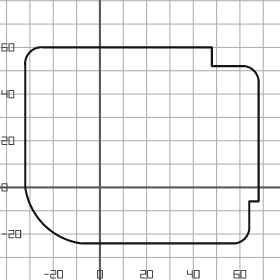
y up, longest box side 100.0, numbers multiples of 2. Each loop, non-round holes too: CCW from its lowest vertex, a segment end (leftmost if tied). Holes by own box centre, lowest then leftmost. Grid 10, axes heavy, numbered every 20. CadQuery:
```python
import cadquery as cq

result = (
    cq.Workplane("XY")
    .moveTo(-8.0, -24.0)
    .lineTo(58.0, -24.0)
    .threePointArc((62.0, -22.0), (64.0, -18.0))
    .lineTo(64.0, -6.0)
    .lineTo(68.0, -6.0)
    .lineTo(68.0, 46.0)
    .threePointArc((66.0, 50.0), (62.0, 52.0))
    .lineTo(48.0, 52.0)
    .lineTo(48.0, 60.0)
    .lineTo(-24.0, 60.0)
    .threePointArc((-30.0, 58.0), (-32.0, 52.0))
    .lineTo(-32.0, 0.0)
    .threePointArc((-24.0, -16.0), (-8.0, -24.0))
    .close()
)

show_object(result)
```